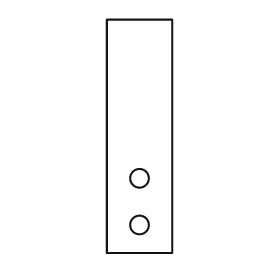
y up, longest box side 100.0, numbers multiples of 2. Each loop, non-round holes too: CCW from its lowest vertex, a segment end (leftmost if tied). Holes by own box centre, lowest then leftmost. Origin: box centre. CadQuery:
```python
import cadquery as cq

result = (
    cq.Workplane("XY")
    .moveTo(-14.0, -50.0)
    .lineTo(14.0, -50.0)
    .lineTo(14.0, 50.0)
    .lineTo(-14.0, 50.0)
    .close()
    .moveTo(0.0, -38.0)
    .circle(4.0)
    .moveTo(0.0, -18.0)
    .circle(4.0)
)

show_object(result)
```